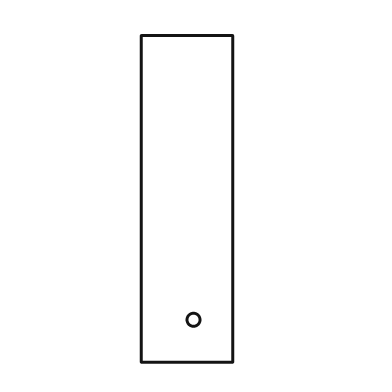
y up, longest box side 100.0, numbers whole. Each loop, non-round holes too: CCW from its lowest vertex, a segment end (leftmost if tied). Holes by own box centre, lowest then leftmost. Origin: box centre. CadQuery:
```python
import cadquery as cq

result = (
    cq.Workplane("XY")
    .moveTo(-14.0, -50.0)
    .lineTo(14.0, -50.0)
    .lineTo(14.0, 50.0)
    .lineTo(-14.0, 50.0)
    .close()
    .moveTo(2.0, -37.0)
    .circle(2.0)
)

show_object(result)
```